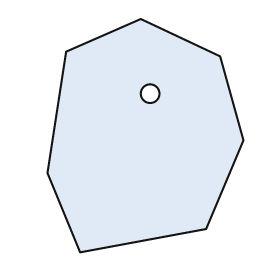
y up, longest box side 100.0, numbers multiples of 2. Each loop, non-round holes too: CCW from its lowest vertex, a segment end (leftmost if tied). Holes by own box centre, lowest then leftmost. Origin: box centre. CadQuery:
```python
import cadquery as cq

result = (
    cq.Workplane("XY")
    .moveTo(-28.0, -50.0)
    .lineTo(26.0, -40.0)
    .lineTo(42.0, -2.0)
    .lineTo(32.0, 34.0)
    .lineTo(-2.0, 50.0)
    .lineTo(-34.0, 36.0)
    .lineTo(-42.0, -16.0)
    .close()
    .moveTo(2.0, 18.0)
    .circle(4.0)
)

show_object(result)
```